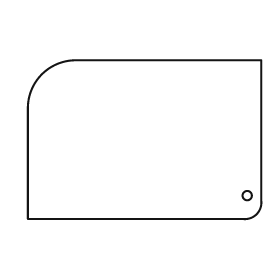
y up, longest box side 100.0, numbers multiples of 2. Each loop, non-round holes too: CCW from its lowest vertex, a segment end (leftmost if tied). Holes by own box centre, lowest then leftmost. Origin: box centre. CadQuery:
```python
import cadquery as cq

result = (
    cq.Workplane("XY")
    .moveTo(-50.0, -34.0)
    .lineTo(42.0, -34.0)
    .threePointArc((48.0, -32.0), (50.0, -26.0))
    .lineTo(50.0, 34.0)
    .lineTo(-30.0, 34.0)
    .threePointArc((-44.0, 28.0), (-50.0, 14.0))
    .close()
    .moveTo(44.0, -24.0)
    .circle(2.0)
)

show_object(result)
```